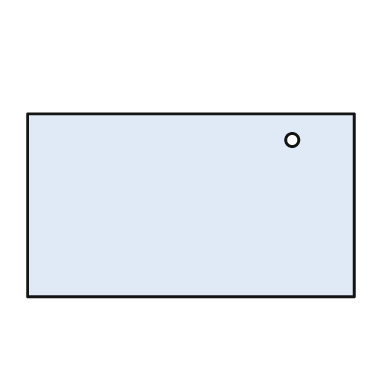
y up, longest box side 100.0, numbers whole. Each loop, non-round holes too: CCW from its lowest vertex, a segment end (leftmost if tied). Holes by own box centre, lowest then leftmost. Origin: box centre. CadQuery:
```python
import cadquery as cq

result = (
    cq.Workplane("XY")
    .moveTo(-50.0, -28.0)
    .lineTo(50.0, -28.0)
    .lineTo(50.0, 28.0)
    .lineTo(-50.0, 28.0)
    .close()
    .moveTo(31.0, 20.0)
    .circle(2.0)
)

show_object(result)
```